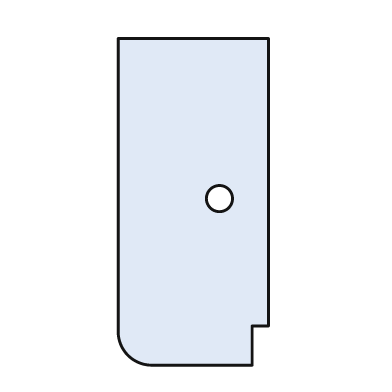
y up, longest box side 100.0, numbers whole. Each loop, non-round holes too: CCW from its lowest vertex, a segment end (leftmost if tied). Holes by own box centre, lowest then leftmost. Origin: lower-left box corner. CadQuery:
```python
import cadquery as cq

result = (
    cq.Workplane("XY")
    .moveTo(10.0, 0.0)
    .lineTo(41.0, 0.0)
    .lineTo(41.0, 12.0)
    .lineTo(46.0, 12.0)
    .lineTo(46.0, 100.0)
    .lineTo(0.0, 100.0)
    .lineTo(0.0, 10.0)
    .threePointArc((3.0, 3.0), (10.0, 0.0))
    .close()
    .moveTo(31.0, 51.0)
    .circle(4.0)
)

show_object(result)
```